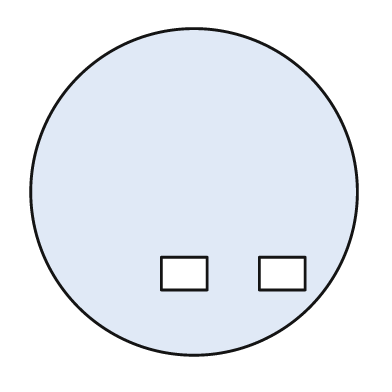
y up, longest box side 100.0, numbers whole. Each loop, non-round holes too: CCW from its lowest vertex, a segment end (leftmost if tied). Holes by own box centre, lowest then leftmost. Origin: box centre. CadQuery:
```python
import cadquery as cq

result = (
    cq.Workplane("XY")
    .moveTo(0.0, 0.0)
    .circle(50.0)
    .moveTo(-10.0, -30.0)
    .lineTo(4.0, -30.0)
    .lineTo(4.0, -20.0)
    .lineTo(-10.0, -20.0)
    .close()
    .moveTo(20.0, -30.0)
    .lineTo(34.0, -30.0)
    .lineTo(34.0, -20.0)
    .lineTo(20.0, -20.0)
    .close()
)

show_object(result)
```